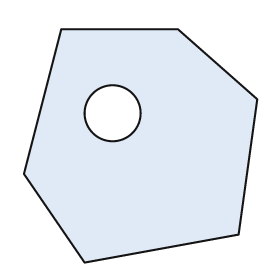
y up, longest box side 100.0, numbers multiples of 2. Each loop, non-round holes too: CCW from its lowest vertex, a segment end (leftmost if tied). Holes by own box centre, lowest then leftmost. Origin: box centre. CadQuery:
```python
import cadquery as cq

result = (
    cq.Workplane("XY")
    .moveTo(-24.0, -50.0)
    .lineTo(42.0, -38.0)
    .lineTo(50.0, 20.0)
    .lineTo(16.0, 50.0)
    .lineTo(-34.0, 50.0)
    .lineTo(-50.0, -12.0)
    .close()
    .moveTo(-12.0, 14.0)
    .circle(12.0)
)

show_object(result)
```